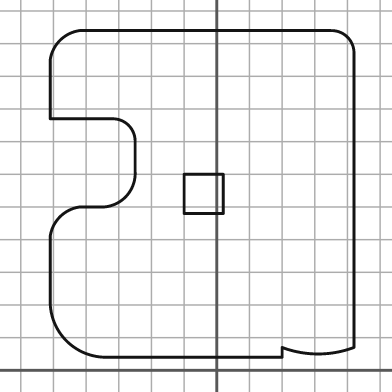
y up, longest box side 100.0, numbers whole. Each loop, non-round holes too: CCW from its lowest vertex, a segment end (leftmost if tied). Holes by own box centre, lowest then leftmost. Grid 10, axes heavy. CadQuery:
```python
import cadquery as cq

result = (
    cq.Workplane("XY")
    .moveTo(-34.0, 4.0)
    .lineTo(20.0, 4.0)
    .lineTo(20.0, 7.0)
    .threePointArc((31.0, 5.0), (42.0, 7.0))
    .lineTo(42.0, 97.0)
    .threePointArc((40.0, 102.0), (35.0, 104.0))
    .lineTo(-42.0, 104.0)
    .threePointArc((-48.0, 101.0), (-51.0, 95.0))
    .lineTo(-51.0, 77.0)
    .lineTo(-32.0, 77.0)
    .threePointArc((-27.0, 75.0), (-25.0, 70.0))
    .lineTo(-25.0, 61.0)
    .threePointArc((-28.0, 53.0), (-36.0, 50.0))
    .lineTo(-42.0, 50.0)
    .threePointArc((-48.0, 47.0), (-51.0, 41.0))
    .lineTo(-51.0, 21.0)
    .threePointArc((-46.0, 9.0), (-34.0, 4.0))
    .close()
    .moveTo(-10.0, 48.0)
    .lineTo(2.0, 48.0)
    .lineTo(2.0, 60.0)
    .lineTo(-10.0, 60.0)
    .close()
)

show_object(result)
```